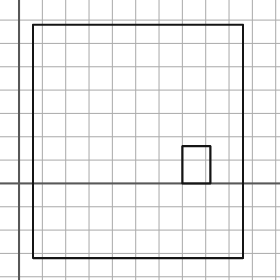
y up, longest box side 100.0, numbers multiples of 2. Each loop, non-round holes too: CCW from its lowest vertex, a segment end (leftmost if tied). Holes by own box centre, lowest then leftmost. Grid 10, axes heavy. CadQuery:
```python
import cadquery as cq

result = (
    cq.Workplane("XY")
    .moveTo(6.0, -32.0)
    .lineTo(96.0, -32.0)
    .lineTo(96.0, 68.0)
    .lineTo(6.0, 68.0)
    .close()
    .moveTo(70.0, 0.0)
    .lineTo(82.0, 0.0)
    .lineTo(82.0, 16.0)
    .lineTo(70.0, 16.0)
    .close()
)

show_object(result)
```